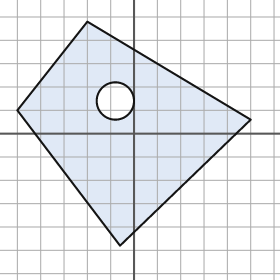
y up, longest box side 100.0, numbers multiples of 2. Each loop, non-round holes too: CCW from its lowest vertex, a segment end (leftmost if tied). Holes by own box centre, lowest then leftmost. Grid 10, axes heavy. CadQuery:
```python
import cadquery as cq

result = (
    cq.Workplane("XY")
    .moveTo(-6.0, -48.0)
    .lineTo(50.0, 6.0)
    .lineTo(-20.0, 48.0)
    .lineTo(-50.0, 10.0)
    .close()
    .moveTo(-8.0, 14.0)
    .circle(8.0)
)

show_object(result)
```